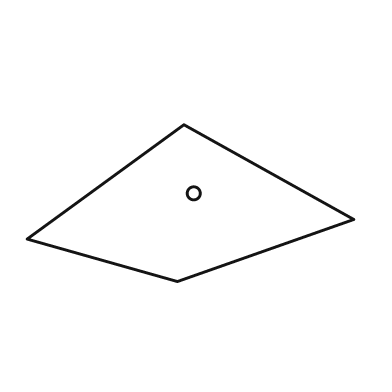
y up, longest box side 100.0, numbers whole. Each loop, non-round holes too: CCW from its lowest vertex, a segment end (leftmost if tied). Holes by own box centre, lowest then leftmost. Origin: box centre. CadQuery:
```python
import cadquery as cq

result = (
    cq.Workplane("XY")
    .moveTo(-4.0, -24.0)
    .lineTo(50.0, -5.0)
    .lineTo(-2.0, 24.0)
    .lineTo(-50.0, -11.0)
    .close()
    .moveTo(1.0, 3.0)
    .circle(2.0)
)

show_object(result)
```